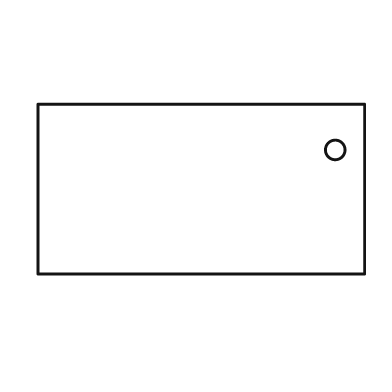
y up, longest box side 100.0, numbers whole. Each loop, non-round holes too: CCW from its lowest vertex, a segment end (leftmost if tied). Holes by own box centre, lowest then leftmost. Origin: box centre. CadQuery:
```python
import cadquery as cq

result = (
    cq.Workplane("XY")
    .moveTo(-50.0, -26.0)
    .lineTo(50.0, -26.0)
    .lineTo(50.0, 26.0)
    .lineTo(-50.0, 26.0)
    .close()
    .moveTo(41.0, 12.0)
    .circle(3.0)
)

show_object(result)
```